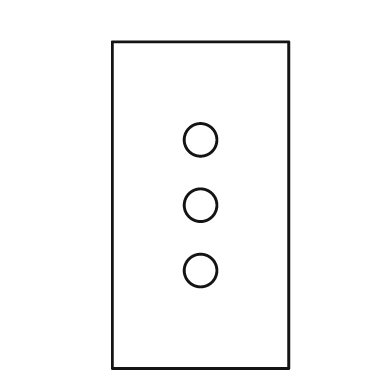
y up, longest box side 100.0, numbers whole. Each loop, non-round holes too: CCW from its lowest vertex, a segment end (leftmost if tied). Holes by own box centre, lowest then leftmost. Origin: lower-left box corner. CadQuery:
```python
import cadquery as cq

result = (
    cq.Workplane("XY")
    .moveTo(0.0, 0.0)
    .lineTo(54.0, 0.0)
    .lineTo(54.0, 100.0)
    .lineTo(0.0, 100.0)
    .close()
    .moveTo(27.0, 30.0)
    .circle(5.0)
    .moveTo(27.0, 50.0)
    .circle(5.0)
    .moveTo(27.0, 70.0)
    .circle(5.0)
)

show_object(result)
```